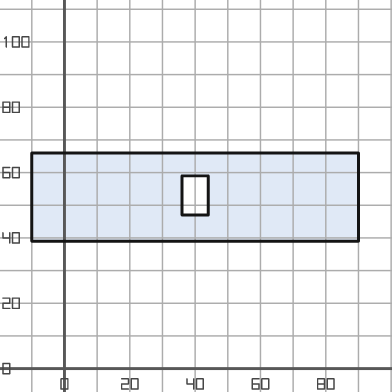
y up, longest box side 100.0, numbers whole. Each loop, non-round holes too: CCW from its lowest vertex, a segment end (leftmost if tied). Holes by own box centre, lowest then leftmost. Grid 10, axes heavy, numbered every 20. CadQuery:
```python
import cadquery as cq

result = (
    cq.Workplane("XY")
    .moveTo(-10.0, 39.0)
    .lineTo(90.0, 39.0)
    .lineTo(90.0, 66.0)
    .lineTo(-10.0, 66.0)
    .close()
    .moveTo(36.0, 47.0)
    .lineTo(44.0, 47.0)
    .lineTo(44.0, 59.0)
    .lineTo(36.0, 59.0)
    .close()
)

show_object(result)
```